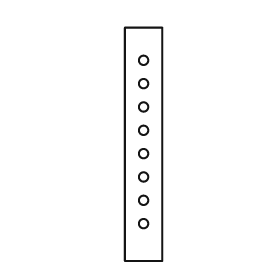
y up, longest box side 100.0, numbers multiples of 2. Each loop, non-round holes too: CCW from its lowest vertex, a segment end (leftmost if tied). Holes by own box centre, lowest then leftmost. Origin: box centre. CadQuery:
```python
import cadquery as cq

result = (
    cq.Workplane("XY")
    .moveTo(-8.0, -50.0)
    .lineTo(8.0, -50.0)
    .lineTo(8.0, 50.0)
    .lineTo(-8.0, 50.0)
    .close()
    .moveTo(0.0, -34.0)
    .circle(2.0)
    .moveTo(0.0, -24.0)
    .circle(2.0)
    .moveTo(0.0, -14.0)
    .circle(2.0)
    .moveTo(0.0, -4.0)
    .circle(2.0)
    .moveTo(0.0, 6.0)
    .circle(2.0)
    .moveTo(0.0, 16.0)
    .circle(2.0)
    .moveTo(0.0, 26.0)
    .circle(2.0)
    .moveTo(0.0, 36.0)
    .circle(2.0)
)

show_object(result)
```